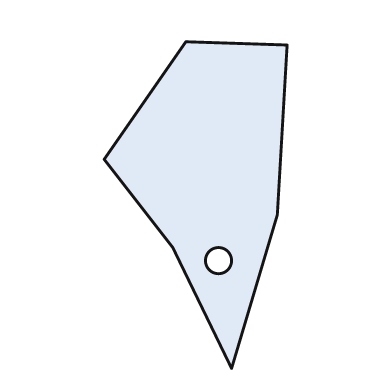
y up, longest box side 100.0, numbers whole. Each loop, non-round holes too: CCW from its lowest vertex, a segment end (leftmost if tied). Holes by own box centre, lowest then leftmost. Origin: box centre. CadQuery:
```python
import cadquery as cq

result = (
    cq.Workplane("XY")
    .moveTo(11.0, -50.0)
    .lineTo(25.0, -3.0)
    .lineTo(28.0, 49.0)
    .lineTo(-3.0, 50.0)
    .lineTo(-28.0, 14.0)
    .lineTo(-7.0, -13.0)
    .close()
    .moveTo(7.0, -17.0)
    .circle(4.0)
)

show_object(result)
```